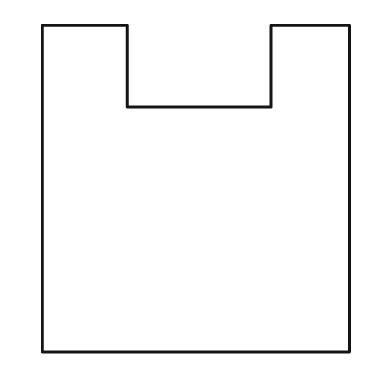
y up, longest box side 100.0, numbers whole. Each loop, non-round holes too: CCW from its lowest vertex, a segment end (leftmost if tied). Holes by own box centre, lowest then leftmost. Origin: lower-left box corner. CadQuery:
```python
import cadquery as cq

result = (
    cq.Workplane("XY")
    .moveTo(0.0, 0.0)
    .lineTo(94.0, 0.0)
    .lineTo(94.0, 100.0)
    .lineTo(70.0, 100.0)
    .lineTo(70.0, 75.0)
    .lineTo(26.0, 75.0)
    .lineTo(26.0, 100.0)
    .lineTo(0.0, 100.0)
    .close()
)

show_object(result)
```